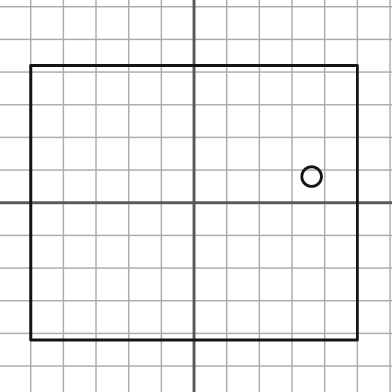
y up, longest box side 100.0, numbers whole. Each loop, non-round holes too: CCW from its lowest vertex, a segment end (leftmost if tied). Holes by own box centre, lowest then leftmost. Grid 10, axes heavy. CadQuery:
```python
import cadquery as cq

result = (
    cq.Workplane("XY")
    .moveTo(-50.0, -42.0)
    .lineTo(50.0, -42.0)
    .lineTo(50.0, 42.0)
    .lineTo(-50.0, 42.0)
    .close()
    .moveTo(36.0, 8.0)
    .circle(3.0)
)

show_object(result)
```